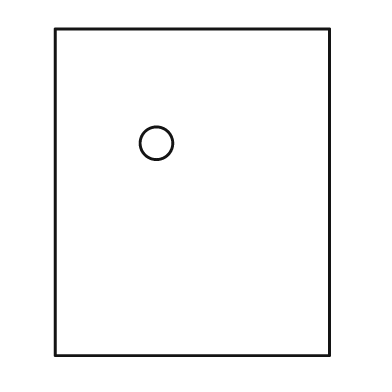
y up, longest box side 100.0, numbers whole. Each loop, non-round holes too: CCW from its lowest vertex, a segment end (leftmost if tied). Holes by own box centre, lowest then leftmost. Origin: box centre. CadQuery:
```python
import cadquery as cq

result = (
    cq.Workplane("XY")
    .moveTo(-42.0, -50.0)
    .lineTo(42.0, -50.0)
    .lineTo(42.0, 50.0)
    .lineTo(-42.0, 50.0)
    .close()
    .moveTo(-11.0, 15.0)
    .circle(5.0)
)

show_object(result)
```